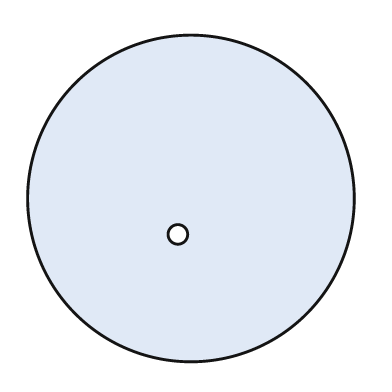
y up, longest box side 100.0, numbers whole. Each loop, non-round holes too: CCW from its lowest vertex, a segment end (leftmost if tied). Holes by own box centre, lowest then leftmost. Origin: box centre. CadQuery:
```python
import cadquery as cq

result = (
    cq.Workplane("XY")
    .moveTo(0.0, 0.0)
    .circle(50.0)
    .moveTo(-4.0, -11.0)
    .circle(3.0)
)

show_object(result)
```